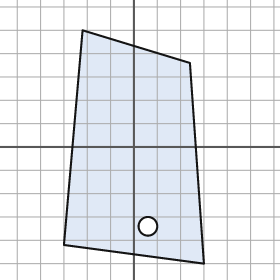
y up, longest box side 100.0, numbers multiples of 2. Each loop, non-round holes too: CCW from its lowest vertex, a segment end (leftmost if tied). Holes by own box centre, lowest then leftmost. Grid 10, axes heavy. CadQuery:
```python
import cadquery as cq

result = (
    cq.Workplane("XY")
    .moveTo(30.0, -50.0)
    .lineTo(24.0, 36.0)
    .lineTo(-22.0, 50.0)
    .lineTo(-30.0, -42.0)
    .close()
    .moveTo(6.0, -34.0)
    .circle(4.0)
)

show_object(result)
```